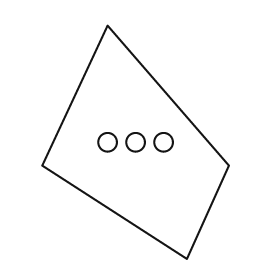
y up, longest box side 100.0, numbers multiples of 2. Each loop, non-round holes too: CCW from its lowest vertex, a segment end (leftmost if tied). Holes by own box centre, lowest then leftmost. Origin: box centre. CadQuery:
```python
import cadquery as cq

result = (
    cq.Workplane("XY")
    .moveTo(22.0, -50.0)
    .lineTo(40.0, -10.0)
    .lineTo(-12.0, 50.0)
    .lineTo(-40.0, -10.0)
    .close()
    .moveTo(-12.0, 0.0)
    .circle(4.0)
    .moveTo(0.0, 0.0)
    .circle(4.0)
    .moveTo(12.0, 0.0)
    .circle(4.0)
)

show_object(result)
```